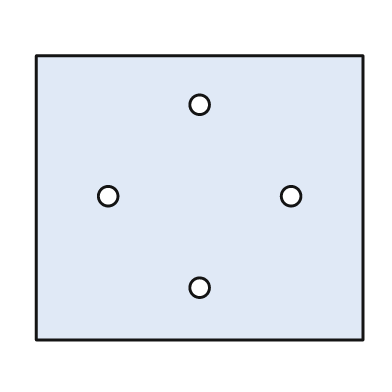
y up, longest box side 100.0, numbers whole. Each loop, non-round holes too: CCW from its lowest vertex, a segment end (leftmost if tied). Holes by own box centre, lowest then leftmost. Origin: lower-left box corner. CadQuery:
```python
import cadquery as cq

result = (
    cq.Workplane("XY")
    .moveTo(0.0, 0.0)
    .lineTo(100.0, 0.0)
    .lineTo(100.0, 87.0)
    .lineTo(0.0, 87.0)
    .close()
    .moveTo(50.0, 16.0)
    .circle(3.0)
    .moveTo(22.0, 44.0)
    .circle(3.0)
    .moveTo(78.0, 44.0)
    .circle(3.0)
    .moveTo(50.0, 72.0)
    .circle(3.0)
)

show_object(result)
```